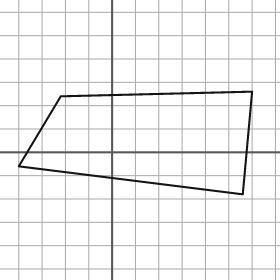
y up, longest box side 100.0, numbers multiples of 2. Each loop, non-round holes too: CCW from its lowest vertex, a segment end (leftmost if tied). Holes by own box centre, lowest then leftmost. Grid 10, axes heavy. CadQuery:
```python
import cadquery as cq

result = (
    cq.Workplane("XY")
    .moveTo(56.0, -18.0)
    .lineTo(60.0, 26.0)
    .lineTo(-22.0, 24.0)
    .lineTo(-40.0, -6.0)
    .close()
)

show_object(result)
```